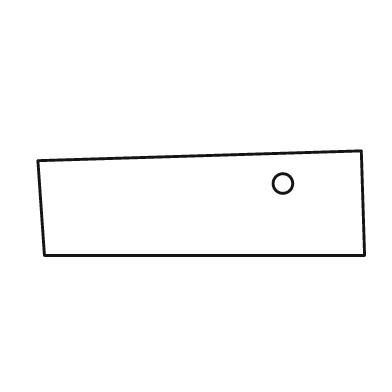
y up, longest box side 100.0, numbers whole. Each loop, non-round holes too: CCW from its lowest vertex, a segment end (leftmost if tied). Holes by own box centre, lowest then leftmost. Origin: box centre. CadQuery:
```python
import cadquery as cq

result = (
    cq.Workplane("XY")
    .moveTo(-48.0, -16.0)
    .lineTo(50.0, -16.0)
    .lineTo(49.0, 16.0)
    .lineTo(-50.0, 13.0)
    .close()
    .moveTo(25.0, 6.0)
    .circle(3.0)
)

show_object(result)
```